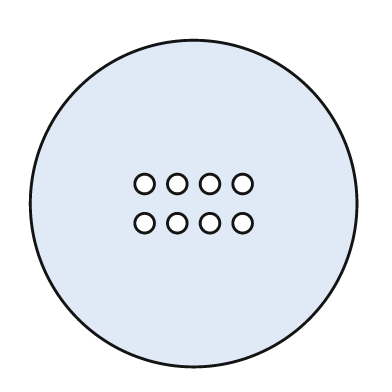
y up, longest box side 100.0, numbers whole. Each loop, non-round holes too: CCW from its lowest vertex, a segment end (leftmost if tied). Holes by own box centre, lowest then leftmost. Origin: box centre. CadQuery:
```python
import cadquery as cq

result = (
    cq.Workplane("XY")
    .moveTo(0.0, 0.0)
    .circle(50.0)
    .moveTo(-15.0, -6.0)
    .circle(3.0)
    .moveTo(-5.0, -6.0)
    .circle(3.0)
    .moveTo(5.0, -6.0)
    .circle(3.0)
    .moveTo(15.0, -6.0)
    .circle(3.0)
    .moveTo(-15.0, 6.0)
    .circle(3.0)
    .moveTo(-5.0, 6.0)
    .circle(3.0)
    .moveTo(5.0, 6.0)
    .circle(3.0)
    .moveTo(15.0, 6.0)
    .circle(3.0)
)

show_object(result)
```